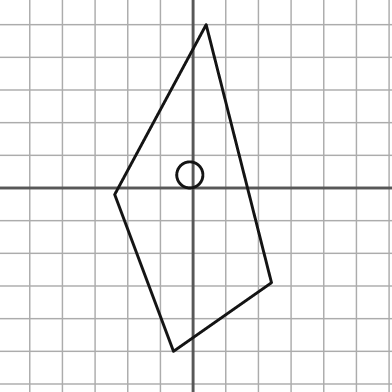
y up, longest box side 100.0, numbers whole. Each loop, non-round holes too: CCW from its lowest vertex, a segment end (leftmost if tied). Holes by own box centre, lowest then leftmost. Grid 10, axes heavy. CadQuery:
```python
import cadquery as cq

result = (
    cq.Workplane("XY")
    .moveTo(-6.0, -50.0)
    .lineTo(24.0, -29.0)
    .lineTo(4.0, 50.0)
    .lineTo(-24.0, -2.0)
    .close()
    .moveTo(-1.0, 4.0)
    .circle(4.0)
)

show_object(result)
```